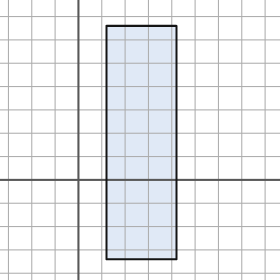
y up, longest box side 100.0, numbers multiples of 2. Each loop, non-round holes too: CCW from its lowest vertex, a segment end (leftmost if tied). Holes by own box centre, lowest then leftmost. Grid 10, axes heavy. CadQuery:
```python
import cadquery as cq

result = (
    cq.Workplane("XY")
    .moveTo(12.0, -34.0)
    .lineTo(42.0, -34.0)
    .lineTo(42.0, 66.0)
    .lineTo(12.0, 66.0)
    .close()
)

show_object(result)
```